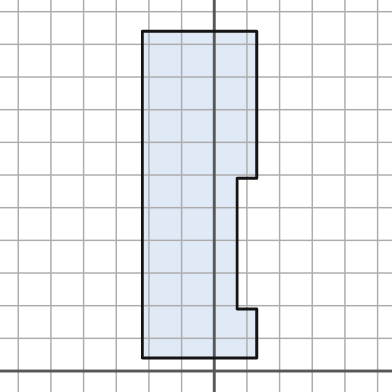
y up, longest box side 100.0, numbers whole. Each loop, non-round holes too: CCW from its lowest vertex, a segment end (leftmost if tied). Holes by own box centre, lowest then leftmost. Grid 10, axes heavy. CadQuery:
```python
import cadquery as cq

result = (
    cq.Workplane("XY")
    .moveTo(-22.0, 4.0)
    .lineTo(13.0, 4.0)
    .lineTo(13.0, 19.0)
    .lineTo(7.0, 19.0)
    .lineTo(7.0, 59.0)
    .lineTo(13.0, 59.0)
    .lineTo(13.0, 104.0)
    .lineTo(-22.0, 104.0)
    .close()
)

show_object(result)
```